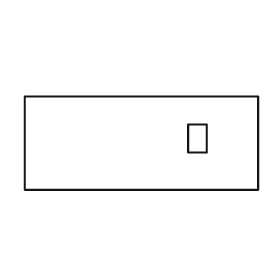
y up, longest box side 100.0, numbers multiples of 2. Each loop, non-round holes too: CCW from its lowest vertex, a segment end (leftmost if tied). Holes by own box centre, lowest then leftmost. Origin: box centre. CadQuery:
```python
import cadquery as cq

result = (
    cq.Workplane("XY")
    .moveTo(-50.0, -20.0)
    .lineTo(50.0, -20.0)
    .lineTo(50.0, 20.0)
    .lineTo(-50.0, 20.0)
    .close()
    .moveTo(20.0, -4.0)
    .lineTo(28.0, -4.0)
    .lineTo(28.0, 8.0)
    .lineTo(20.0, 8.0)
    .close()
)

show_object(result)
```